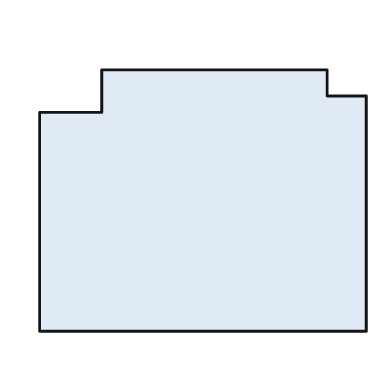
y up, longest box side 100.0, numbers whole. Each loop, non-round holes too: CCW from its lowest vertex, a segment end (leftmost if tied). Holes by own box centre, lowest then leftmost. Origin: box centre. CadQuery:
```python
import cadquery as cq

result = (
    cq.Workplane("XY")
    .moveTo(-50.0, -40.0)
    .lineTo(50.0, -40.0)
    .lineTo(50.0, 32.0)
    .lineTo(38.0, 32.0)
    .lineTo(38.0, 40.0)
    .lineTo(-31.0, 40.0)
    .lineTo(-31.0, 27.0)
    .lineTo(-50.0, 27.0)
    .close()
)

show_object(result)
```